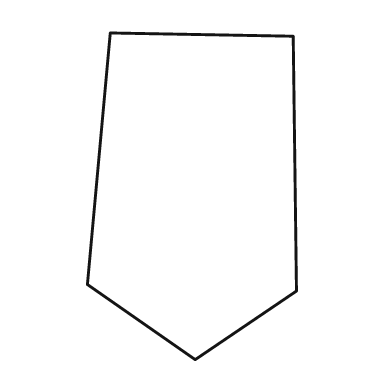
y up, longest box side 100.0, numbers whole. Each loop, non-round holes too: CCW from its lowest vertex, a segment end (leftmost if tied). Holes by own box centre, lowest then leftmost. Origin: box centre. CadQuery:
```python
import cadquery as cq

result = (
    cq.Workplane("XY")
    .moveTo(1.0, -50.0)
    .lineTo(32.0, -29.0)
    .lineTo(31.0, 49.0)
    .lineTo(-25.0, 50.0)
    .lineTo(-32.0, -27.0)
    .close()
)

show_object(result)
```